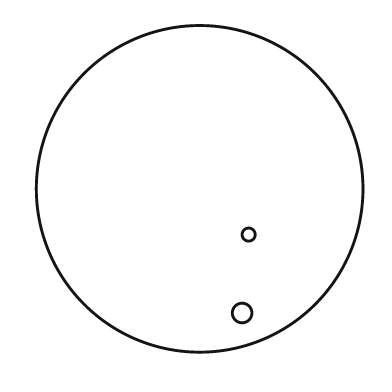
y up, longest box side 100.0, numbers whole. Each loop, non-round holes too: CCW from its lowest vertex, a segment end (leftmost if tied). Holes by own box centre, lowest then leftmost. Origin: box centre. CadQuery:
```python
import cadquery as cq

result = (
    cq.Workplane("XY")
    .moveTo(0.0, 0.0)
    .circle(50.0)
    .moveTo(13.0, -38.0)
    .circle(3.0)
    .moveTo(15.0, -14.0)
    .circle(2.0)
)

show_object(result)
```